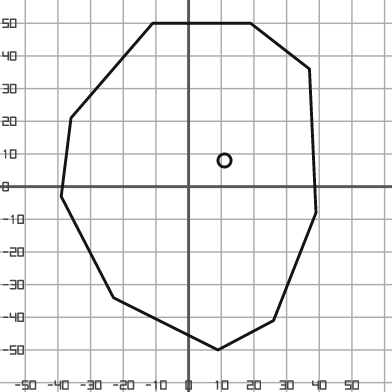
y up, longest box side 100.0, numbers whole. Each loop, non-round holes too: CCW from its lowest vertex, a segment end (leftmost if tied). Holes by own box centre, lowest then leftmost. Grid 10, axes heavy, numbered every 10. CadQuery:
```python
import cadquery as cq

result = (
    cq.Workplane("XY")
    .moveTo(9.0, -50.0)
    .lineTo(26.0, -41.0)
    .lineTo(39.0, -8.0)
    .lineTo(37.0, 36.0)
    .lineTo(19.0, 50.0)
    .lineTo(-11.0, 50.0)
    .lineTo(-36.0, 21.0)
    .lineTo(-39.0, -3.0)
    .lineTo(-23.0, -34.0)
    .close()
    .moveTo(11.0, 8.0)
    .circle(2.0)
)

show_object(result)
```